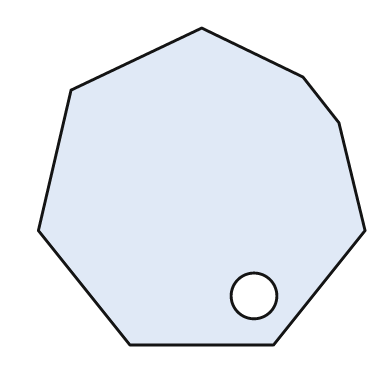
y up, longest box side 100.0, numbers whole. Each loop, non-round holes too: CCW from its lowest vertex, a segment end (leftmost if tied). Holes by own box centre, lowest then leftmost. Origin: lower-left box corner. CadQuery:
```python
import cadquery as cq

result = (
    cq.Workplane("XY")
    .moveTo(28.0, 0.0)
    .lineTo(72.0, 0.0)
    .lineTo(100.0, 35.0)
    .lineTo(92.0, 68.0)
    .lineTo(81.0, 82.0)
    .lineTo(50.0, 97.0)
    .lineTo(10.0, 78.0)
    .lineTo(0.0, 35.0)
    .close()
    .moveTo(66.0, 15.0)
    .circle(7.0)
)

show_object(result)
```